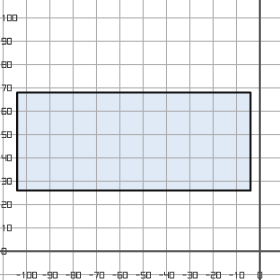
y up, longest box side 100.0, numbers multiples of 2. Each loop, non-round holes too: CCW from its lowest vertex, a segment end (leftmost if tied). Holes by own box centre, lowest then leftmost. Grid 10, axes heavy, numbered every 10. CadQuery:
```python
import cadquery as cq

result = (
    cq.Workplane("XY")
    .moveTo(-104.0, 26.0)
    .lineTo(-4.0, 26.0)
    .lineTo(-4.0, 68.0)
    .lineTo(-104.0, 68.0)
    .close()
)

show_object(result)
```